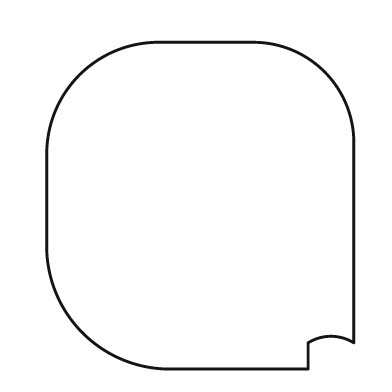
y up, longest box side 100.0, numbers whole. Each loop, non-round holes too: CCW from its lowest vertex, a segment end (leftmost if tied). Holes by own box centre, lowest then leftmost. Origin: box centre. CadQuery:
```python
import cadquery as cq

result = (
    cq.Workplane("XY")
    .moveTo(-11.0, -50.0)
    .lineTo(33.0, -50.0)
    .lineTo(33.0, -42.0)
    .threePointArc((40.0, -40.0), (47.0, -42.0))
    .lineTo(47.0, 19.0)
    .threePointArc((38.0, 41.0), (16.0, 50.0))
    .lineTo(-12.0, 50.0)
    .threePointArc((-37.0, 40.0), (-47.0, 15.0))
    .lineTo(-47.0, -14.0)
    .threePointArc((-36.0, -39.0), (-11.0, -50.0))
    .close()
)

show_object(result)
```